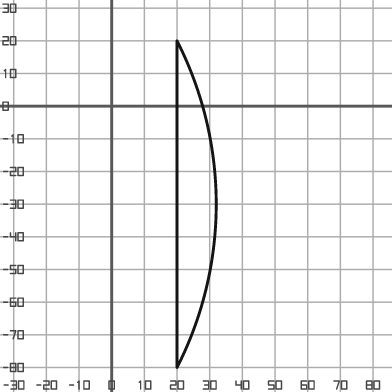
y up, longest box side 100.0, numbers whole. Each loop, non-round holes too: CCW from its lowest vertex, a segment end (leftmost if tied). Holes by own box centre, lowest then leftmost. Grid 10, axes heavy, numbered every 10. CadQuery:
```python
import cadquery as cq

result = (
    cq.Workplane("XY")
    .moveTo(20.0, -80.0)
    .threePointArc((32.0, -30.0), (20.0, 20.0))
    .close()
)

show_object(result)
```